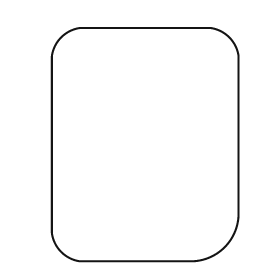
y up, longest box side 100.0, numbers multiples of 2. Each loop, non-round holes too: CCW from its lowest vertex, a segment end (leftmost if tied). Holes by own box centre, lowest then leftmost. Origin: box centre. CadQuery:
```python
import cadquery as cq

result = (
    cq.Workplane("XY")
    .moveTo(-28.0, -50.0)
    .lineTo(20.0, -50.0)
    .threePointArc((34.0, -44.0), (40.0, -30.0))
    .lineTo(40.0, 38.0)
    .threePointArc((36.0, 46.0), (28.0, 50.0))
    .lineTo(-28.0, 50.0)
    .threePointArc((-36.0, 46.0), (-40.0, 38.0))
    .lineTo(-40.0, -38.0)
    .threePointArc((-36.0, -46.0), (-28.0, -50.0))
    .close()
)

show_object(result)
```